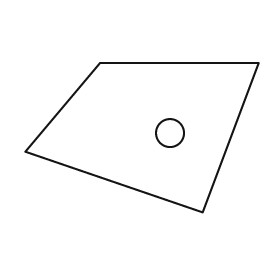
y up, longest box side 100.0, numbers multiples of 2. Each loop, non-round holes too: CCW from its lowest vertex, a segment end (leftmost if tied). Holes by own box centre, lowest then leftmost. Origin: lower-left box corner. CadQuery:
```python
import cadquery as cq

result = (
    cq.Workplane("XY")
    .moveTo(76.0, 0.0)
    .lineTo(100.0, 64.0)
    .lineTo(32.0, 64.0)
    .lineTo(0.0, 26.0)
    .close()
    .moveTo(62.0, 34.0)
    .circle(6.0)
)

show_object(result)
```